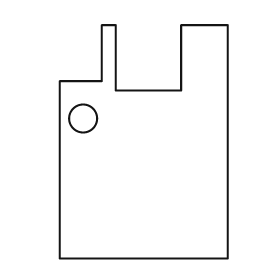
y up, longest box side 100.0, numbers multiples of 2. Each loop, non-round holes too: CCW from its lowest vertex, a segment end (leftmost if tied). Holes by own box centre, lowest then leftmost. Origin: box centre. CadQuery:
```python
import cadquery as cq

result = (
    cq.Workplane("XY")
    .moveTo(-36.0, -50.0)
    .lineTo(36.0, -50.0)
    .lineTo(36.0, 50.0)
    .lineTo(16.0, 50.0)
    .lineTo(16.0, 22.0)
    .lineTo(-12.0, 22.0)
    .lineTo(-12.0, 50.0)
    .lineTo(-18.0, 50.0)
    .lineTo(-18.0, 26.0)
    .lineTo(-36.0, 26.0)
    .close()
    .moveTo(-26.0, 10.0)
    .circle(6.0)
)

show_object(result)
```